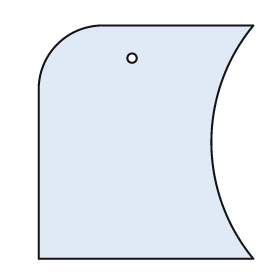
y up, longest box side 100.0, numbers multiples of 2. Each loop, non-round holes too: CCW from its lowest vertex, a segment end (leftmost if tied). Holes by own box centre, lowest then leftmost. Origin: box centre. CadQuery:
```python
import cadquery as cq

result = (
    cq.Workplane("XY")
    .moveTo(-46.0, -50.0)
    .lineTo(46.0, -50.0)
    .threePointArc((28.0, 0.0), (46.0, 50.0))
    .lineTo(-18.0, 50.0)
    .threePointArc((-38.0, 42.0), (-46.0, 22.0))
    .close()
    .moveTo(-6.0, 36.0)
    .circle(2.0)
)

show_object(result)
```